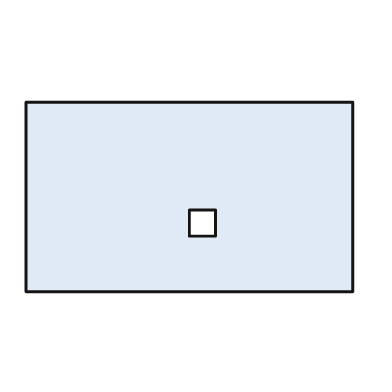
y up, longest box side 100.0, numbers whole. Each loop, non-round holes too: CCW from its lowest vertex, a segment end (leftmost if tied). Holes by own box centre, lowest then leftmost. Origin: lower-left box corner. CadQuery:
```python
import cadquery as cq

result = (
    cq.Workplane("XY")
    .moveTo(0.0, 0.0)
    .lineTo(100.0, 0.0)
    .lineTo(100.0, 58.0)
    .lineTo(0.0, 58.0)
    .close()
    .moveTo(50.0, 17.0)
    .lineTo(58.0, 17.0)
    .lineTo(58.0, 25.0)
    .lineTo(50.0, 25.0)
    .close()
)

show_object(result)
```